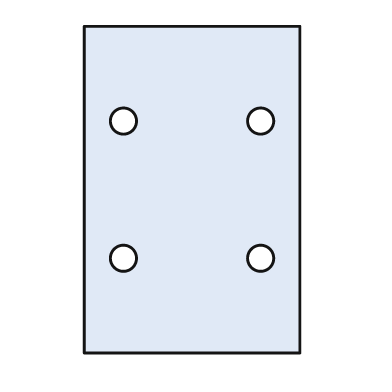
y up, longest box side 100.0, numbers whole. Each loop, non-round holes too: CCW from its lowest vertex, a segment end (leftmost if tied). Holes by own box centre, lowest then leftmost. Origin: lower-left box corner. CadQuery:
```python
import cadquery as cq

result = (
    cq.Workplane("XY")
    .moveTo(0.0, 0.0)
    .lineTo(66.0, 0.0)
    .lineTo(66.0, 100.0)
    .lineTo(0.0, 100.0)
    .close()
    .moveTo(12.0, 29.0)
    .circle(4.0)
    .moveTo(54.0, 29.0)
    .circle(4.0)
    .moveTo(12.0, 71.0)
    .circle(4.0)
    .moveTo(54.0, 71.0)
    .circle(4.0)
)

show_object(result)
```